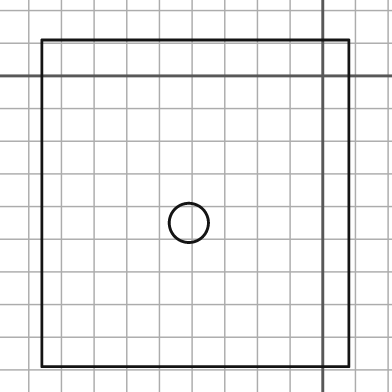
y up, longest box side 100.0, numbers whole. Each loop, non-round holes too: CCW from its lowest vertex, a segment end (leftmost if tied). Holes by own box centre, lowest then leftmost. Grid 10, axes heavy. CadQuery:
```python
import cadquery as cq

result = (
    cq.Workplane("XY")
    .moveTo(-86.0, -89.0)
    .lineTo(8.0, -89.0)
    .lineTo(8.0, 11.0)
    .lineTo(-86.0, 11.0)
    .close()
    .moveTo(-41.0, -45.0)
    .circle(6.0)
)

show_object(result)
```